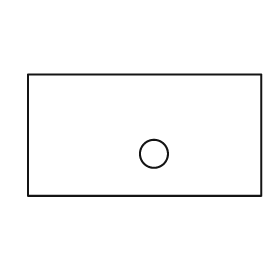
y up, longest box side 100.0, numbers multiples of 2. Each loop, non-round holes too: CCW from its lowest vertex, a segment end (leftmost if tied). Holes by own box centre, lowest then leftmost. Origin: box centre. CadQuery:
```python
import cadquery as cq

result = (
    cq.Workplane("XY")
    .moveTo(-50.0, -26.0)
    .lineTo(50.0, -26.0)
    .lineTo(50.0, 26.0)
    .lineTo(-50.0, 26.0)
    .close()
    .moveTo(4.0, -8.0)
    .circle(6.0)
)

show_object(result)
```